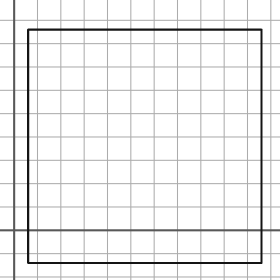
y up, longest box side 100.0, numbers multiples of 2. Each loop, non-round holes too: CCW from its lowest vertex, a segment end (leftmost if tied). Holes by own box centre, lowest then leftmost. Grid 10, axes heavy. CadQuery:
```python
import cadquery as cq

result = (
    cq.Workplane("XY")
    .moveTo(6.0, -14.0)
    .lineTo(106.0, -14.0)
    .lineTo(106.0, 86.0)
    .lineTo(6.0, 86.0)
    .close()
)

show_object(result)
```